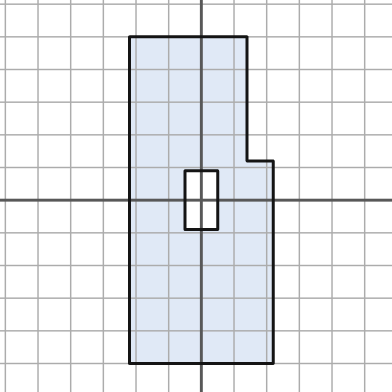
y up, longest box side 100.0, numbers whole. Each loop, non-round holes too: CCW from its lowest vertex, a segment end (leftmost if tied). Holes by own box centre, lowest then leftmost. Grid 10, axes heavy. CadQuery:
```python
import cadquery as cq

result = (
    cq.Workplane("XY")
    .moveTo(-22.0, -50.0)
    .lineTo(22.0, -50.0)
    .lineTo(22.0, 12.0)
    .lineTo(14.0, 12.0)
    .lineTo(14.0, 50.0)
    .lineTo(-22.0, 50.0)
    .close()
    .moveTo(-5.0, -9.0)
    .lineTo(5.0, -9.0)
    .lineTo(5.0, 9.0)
    .lineTo(-5.0, 9.0)
    .close()
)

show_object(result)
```